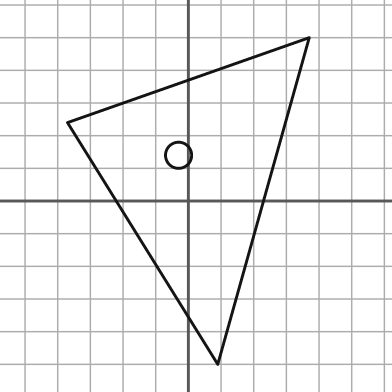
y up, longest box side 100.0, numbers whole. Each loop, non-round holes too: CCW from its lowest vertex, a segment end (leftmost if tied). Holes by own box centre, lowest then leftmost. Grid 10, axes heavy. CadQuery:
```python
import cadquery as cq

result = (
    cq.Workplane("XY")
    .moveTo(9.0, -50.0)
    .lineTo(37.0, 50.0)
    .lineTo(-37.0, 24.0)
    .close()
    .moveTo(-3.0, 14.0)
    .circle(4.0)
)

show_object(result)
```